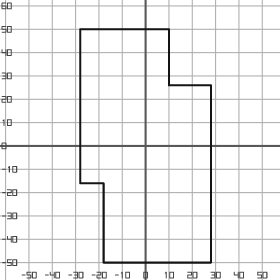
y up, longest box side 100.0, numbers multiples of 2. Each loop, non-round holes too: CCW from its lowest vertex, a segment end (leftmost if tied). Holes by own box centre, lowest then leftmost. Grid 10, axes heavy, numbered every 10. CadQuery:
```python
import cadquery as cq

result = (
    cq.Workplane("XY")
    .moveTo(-18.0, -50.0)
    .lineTo(28.0, -50.0)
    .lineTo(28.0, 26.0)
    .lineTo(10.0, 26.0)
    .lineTo(10.0, 50.0)
    .lineTo(-28.0, 50.0)
    .lineTo(-28.0, -16.0)
    .lineTo(-18.0, -16.0)
    .close()
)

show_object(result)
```